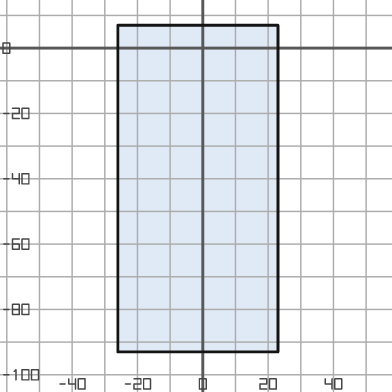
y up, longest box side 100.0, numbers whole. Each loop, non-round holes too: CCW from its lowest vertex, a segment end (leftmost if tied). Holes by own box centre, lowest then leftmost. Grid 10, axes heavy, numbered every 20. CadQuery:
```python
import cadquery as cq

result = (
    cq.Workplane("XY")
    .moveTo(-26.0, -93.0)
    .lineTo(23.0, -93.0)
    .lineTo(23.0, 7.0)
    .lineTo(-26.0, 7.0)
    .close()
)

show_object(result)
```